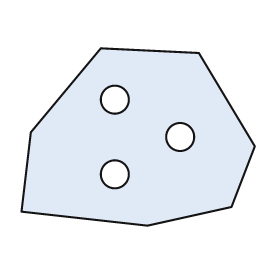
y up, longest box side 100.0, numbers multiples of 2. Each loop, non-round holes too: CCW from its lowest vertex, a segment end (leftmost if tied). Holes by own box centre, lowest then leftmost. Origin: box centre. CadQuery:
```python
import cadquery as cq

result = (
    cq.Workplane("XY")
    .moveTo(4.0, -38.0)
    .lineTo(40.0, -30.0)
    .lineTo(50.0, -4.0)
    .lineTo(26.0, 36.0)
    .lineTo(-16.0, 38.0)
    .lineTo(-46.0, 2.0)
    .lineTo(-50.0, -32.0)
    .close()
    .moveTo(-10.0, -16.0)
    .circle(6.0)
    .moveTo(18.0, 0.0)
    .circle(6.0)
    .moveTo(-10.0, 16.0)
    .circle(6.0)
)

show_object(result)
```